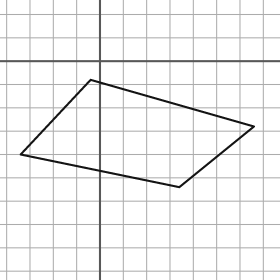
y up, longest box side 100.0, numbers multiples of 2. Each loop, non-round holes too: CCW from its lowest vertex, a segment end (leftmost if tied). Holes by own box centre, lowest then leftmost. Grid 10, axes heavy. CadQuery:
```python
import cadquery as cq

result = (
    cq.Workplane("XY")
    .moveTo(34.0, -54.0)
    .lineTo(66.0, -28.0)
    .lineTo(-4.0, -8.0)
    .lineTo(-34.0, -40.0)
    .close()
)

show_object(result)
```